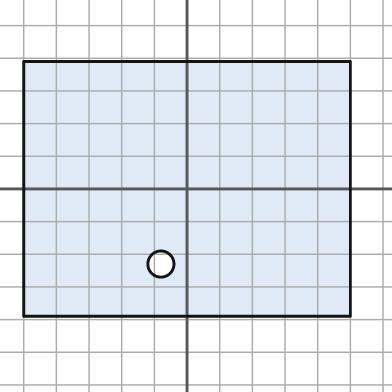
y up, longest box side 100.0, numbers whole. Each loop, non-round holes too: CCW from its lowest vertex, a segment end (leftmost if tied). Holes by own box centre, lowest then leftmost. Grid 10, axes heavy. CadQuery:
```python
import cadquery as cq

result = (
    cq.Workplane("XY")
    .moveTo(-50.0, -39.0)
    .lineTo(50.0, -39.0)
    .lineTo(50.0, 39.0)
    .lineTo(-50.0, 39.0)
    .close()
    .moveTo(-8.0, -23.0)
    .circle(4.0)
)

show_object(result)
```